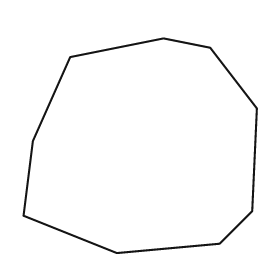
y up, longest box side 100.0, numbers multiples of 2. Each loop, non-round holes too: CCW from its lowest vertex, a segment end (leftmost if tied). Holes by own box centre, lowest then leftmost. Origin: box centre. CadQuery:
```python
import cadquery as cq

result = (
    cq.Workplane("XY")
    .moveTo(-10.0, -46.0)
    .lineTo(34.0, -42.0)
    .lineTo(48.0, -28.0)
    .lineTo(50.0, 16.0)
    .lineTo(30.0, 42.0)
    .lineTo(10.0, 46.0)
    .lineTo(-30.0, 38.0)
    .lineTo(-46.0, 2.0)
    .lineTo(-50.0, -30.0)
    .close()
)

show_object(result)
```